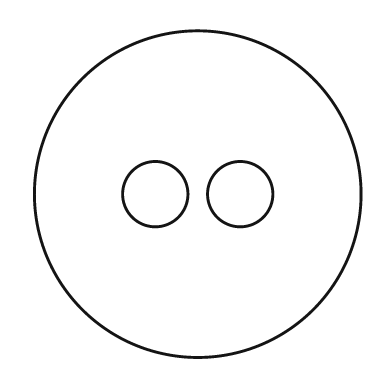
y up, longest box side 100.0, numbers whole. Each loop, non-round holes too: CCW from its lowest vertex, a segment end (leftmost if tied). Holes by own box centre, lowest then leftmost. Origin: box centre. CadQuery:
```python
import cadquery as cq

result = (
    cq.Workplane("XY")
    .moveTo(0.0, 0.0)
    .circle(50.0)
    .moveTo(-13.0, 0.0)
    .circle(10.0)
    .moveTo(13.0, 0.0)
    .circle(10.0)
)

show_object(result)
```